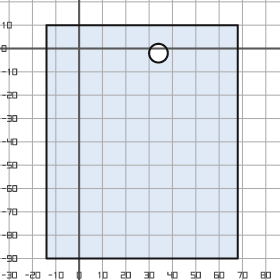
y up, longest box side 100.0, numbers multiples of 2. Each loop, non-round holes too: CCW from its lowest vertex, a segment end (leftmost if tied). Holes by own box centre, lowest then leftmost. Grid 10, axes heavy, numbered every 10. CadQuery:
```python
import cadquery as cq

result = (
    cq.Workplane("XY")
    .moveTo(-14.0, -90.0)
    .lineTo(68.0, -90.0)
    .lineTo(68.0, 10.0)
    .lineTo(-14.0, 10.0)
    .close()
    .moveTo(34.0, -2.0)
    .circle(4.0)
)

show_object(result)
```